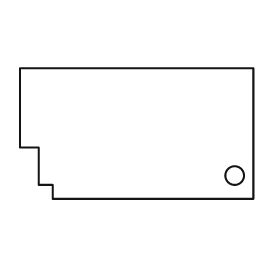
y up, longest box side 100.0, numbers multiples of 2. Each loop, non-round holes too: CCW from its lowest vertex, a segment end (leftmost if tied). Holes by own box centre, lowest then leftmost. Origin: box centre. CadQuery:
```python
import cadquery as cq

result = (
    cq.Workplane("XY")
    .moveTo(-36.0, -28.0)
    .lineTo(50.0, -28.0)
    .lineTo(50.0, 28.0)
    .lineTo(-50.0, 28.0)
    .lineTo(-50.0, -6.0)
    .lineTo(-42.0, -6.0)
    .lineTo(-42.0, -22.0)
    .lineTo(-36.0, -22.0)
    .close()
    .moveTo(42.0, -18.0)
    .circle(4.0)
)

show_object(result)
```